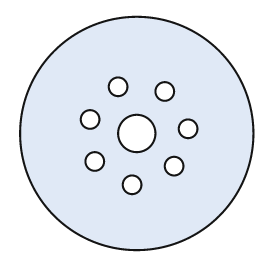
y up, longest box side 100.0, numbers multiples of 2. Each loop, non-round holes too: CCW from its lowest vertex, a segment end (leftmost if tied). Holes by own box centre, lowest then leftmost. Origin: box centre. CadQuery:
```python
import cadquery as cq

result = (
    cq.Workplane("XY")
    .moveTo(0.0, 0.0)
    .circle(50.0)
    .moveTo(-2.0, -22.0)
    .circle(4.0)
    .moveTo(16.0, -14.0)
    .circle(4.0)
    .moveTo(-18.0, -12.0)
    .circle(4.0)
    .moveTo(0.0, 0.0)
    .circle(8.0)
    .moveTo(22.0, 2.0)
    .circle(4.0)
    .moveTo(-20.0, 6.0)
    .circle(4.0)
    .moveTo(12.0, 18.0)
    .circle(4.0)
    .moveTo(-8.0, 20.0)
    .circle(4.0)
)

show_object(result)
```